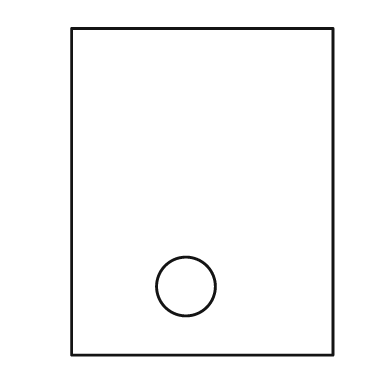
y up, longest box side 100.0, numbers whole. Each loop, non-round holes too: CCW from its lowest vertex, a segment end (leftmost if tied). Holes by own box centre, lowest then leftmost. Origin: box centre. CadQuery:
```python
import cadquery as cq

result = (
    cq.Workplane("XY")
    .moveTo(-40.0, -50.0)
    .lineTo(40.0, -50.0)
    .lineTo(40.0, 50.0)
    .lineTo(-40.0, 50.0)
    .close()
    .moveTo(-5.0, -29.0)
    .circle(9.0)
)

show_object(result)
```